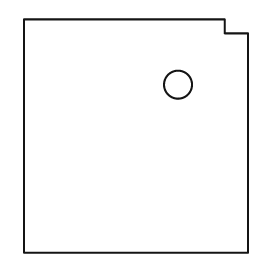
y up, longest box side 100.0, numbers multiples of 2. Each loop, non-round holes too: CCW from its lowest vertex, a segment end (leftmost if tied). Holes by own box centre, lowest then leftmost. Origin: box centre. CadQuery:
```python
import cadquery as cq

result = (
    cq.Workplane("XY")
    .moveTo(-48.0, -50.0)
    .lineTo(48.0, -50.0)
    .lineTo(48.0, 44.0)
    .lineTo(38.0, 44.0)
    .lineTo(38.0, 50.0)
    .lineTo(-48.0, 50.0)
    .close()
    .moveTo(18.0, 22.0)
    .circle(6.0)
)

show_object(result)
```